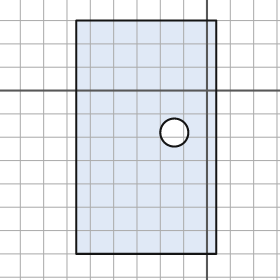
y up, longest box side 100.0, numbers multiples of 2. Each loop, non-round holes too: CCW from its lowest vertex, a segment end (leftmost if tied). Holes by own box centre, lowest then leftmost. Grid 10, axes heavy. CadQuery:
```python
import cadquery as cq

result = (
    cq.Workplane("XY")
    .moveTo(-56.0, -70.0)
    .lineTo(4.0, -70.0)
    .lineTo(4.0, 30.0)
    .lineTo(-56.0, 30.0)
    .close()
    .moveTo(-14.0, -18.0)
    .circle(6.0)
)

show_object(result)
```